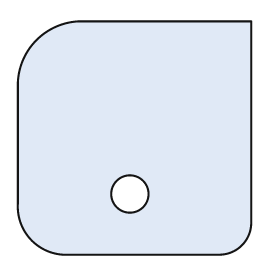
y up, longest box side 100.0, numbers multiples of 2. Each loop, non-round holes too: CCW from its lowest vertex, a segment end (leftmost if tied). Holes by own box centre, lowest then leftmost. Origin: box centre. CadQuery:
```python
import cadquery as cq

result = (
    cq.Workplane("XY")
    .moveTo(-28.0, -50.0)
    .lineTo(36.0, -50.0)
    .threePointArc((46.0, -46.0), (50.0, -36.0))
    .lineTo(50.0, 50.0)
    .lineTo(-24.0, 50.0)
    .threePointArc((-42.0, 42.0), (-50.0, 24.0))
    .lineTo(-50.0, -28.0)
    .threePointArc((-44.0, -44.0), (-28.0, -50.0))
    .close()
    .moveTo(-2.0, -24.0)
    .circle(8.0)
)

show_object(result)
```